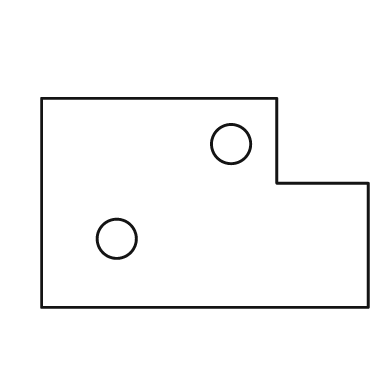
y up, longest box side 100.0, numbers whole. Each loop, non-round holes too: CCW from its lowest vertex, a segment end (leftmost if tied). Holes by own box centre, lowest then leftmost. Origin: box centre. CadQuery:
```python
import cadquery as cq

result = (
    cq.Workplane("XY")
    .moveTo(-50.0, -32.0)
    .lineTo(50.0, -32.0)
    .lineTo(50.0, 6.0)
    .lineTo(22.0, 6.0)
    .lineTo(22.0, 32.0)
    .lineTo(-50.0, 32.0)
    .close()
    .moveTo(-27.0, -11.0)
    .circle(6.0)
    .moveTo(8.0, 18.0)
    .circle(6.0)
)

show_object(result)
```